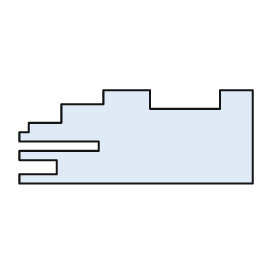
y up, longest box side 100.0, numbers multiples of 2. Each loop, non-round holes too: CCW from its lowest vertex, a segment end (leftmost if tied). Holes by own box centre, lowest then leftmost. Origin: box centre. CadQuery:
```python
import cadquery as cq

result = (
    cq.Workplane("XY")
    .moveTo(-50.0, -20.0)
    .lineTo(50.0, -20.0)
    .lineTo(50.0, 20.0)
    .lineTo(36.0, 20.0)
    .lineTo(36.0, 12.0)
    .lineTo(6.0, 12.0)
    .lineTo(6.0, 20.0)
    .lineTo(-14.0, 20.0)
    .lineTo(-14.0, 14.0)
    .lineTo(-32.0, 14.0)
    .lineTo(-32.0, 6.0)
    .lineTo(-46.0, 6.0)
    .lineTo(-46.0, 2.0)
    .lineTo(-50.0, 2.0)
    .lineTo(-50.0, -2.0)
    .lineTo(-16.0, -2.0)
    .lineTo(-16.0, -6.0)
    .lineTo(-50.0, -6.0)
    .lineTo(-50.0, -10.0)
    .lineTo(-34.0, -10.0)
    .lineTo(-34.0, -16.0)
    .lineTo(-50.0, -16.0)
    .close()
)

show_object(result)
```